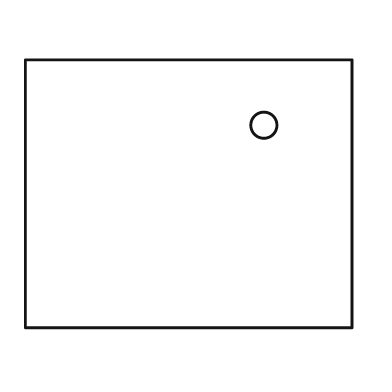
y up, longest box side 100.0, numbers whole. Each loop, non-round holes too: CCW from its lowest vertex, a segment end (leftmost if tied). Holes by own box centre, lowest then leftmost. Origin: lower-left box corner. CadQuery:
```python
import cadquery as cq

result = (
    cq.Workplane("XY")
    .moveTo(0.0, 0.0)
    .lineTo(100.0, 0.0)
    .lineTo(100.0, 82.0)
    .lineTo(0.0, 82.0)
    .close()
    .moveTo(73.0, 62.0)
    .circle(4.0)
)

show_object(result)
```